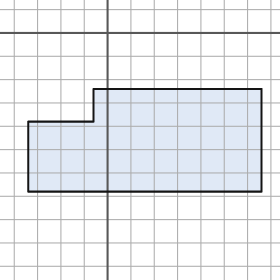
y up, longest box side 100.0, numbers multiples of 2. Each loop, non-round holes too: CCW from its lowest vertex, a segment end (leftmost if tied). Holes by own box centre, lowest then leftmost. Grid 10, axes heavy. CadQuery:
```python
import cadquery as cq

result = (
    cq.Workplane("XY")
    .moveTo(-34.0, -68.0)
    .lineTo(66.0, -68.0)
    .lineTo(66.0, -24.0)
    .lineTo(-6.0, -24.0)
    .lineTo(-6.0, -38.0)
    .lineTo(-34.0, -38.0)
    .close()
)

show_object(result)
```